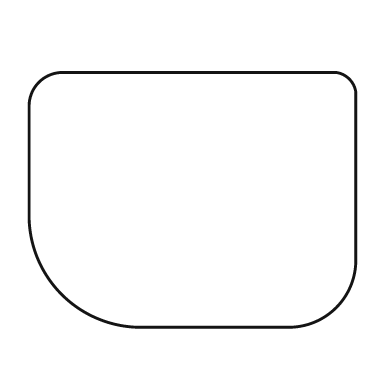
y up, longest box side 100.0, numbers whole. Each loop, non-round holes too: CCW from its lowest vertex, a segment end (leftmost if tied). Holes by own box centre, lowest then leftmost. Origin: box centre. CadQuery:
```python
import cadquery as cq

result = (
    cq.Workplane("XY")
    .moveTo(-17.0, -39.0)
    .lineTo(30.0, -39.0)
    .threePointArc((44.0, -33.0), (50.0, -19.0))
    .lineTo(50.0, 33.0)
    .threePointArc((48.0, 37.0), (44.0, 39.0))
    .lineTo(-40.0, 39.0)
    .threePointArc((-47.0, 36.0), (-50.0, 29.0))
    .lineTo(-50.0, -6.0)
    .threePointArc((-40.0, -29.0), (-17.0, -39.0))
    .close()
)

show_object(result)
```